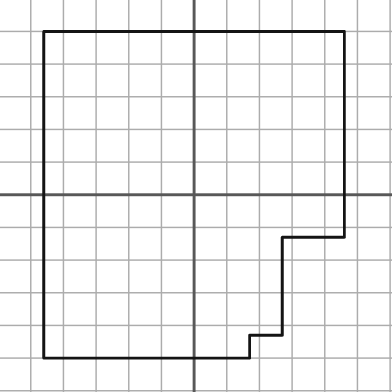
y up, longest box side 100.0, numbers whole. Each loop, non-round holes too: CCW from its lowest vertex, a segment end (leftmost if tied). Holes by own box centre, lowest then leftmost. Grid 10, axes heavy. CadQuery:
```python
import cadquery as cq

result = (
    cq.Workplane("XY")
    .moveTo(-46.0, -50.0)
    .lineTo(17.0, -50.0)
    .lineTo(17.0, -43.0)
    .lineTo(27.0, -43.0)
    .lineTo(27.0, -13.0)
    .lineTo(46.0, -13.0)
    .lineTo(46.0, 50.0)
    .lineTo(-46.0, 50.0)
    .close()
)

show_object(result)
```